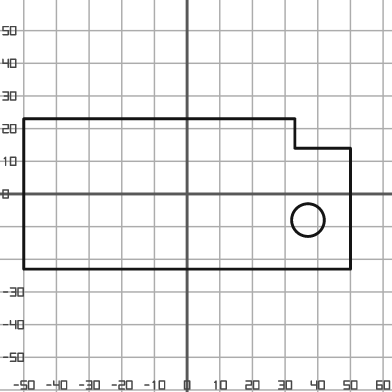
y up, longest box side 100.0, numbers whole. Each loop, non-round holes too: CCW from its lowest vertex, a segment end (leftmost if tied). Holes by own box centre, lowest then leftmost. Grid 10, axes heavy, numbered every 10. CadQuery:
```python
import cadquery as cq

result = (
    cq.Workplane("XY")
    .moveTo(-50.0, -23.0)
    .lineTo(50.0, -23.0)
    .lineTo(50.0, 14.0)
    .lineTo(33.0, 14.0)
    .lineTo(33.0, 23.0)
    .lineTo(-50.0, 23.0)
    .close()
    .moveTo(37.0, -8.0)
    .circle(5.0)
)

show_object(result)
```